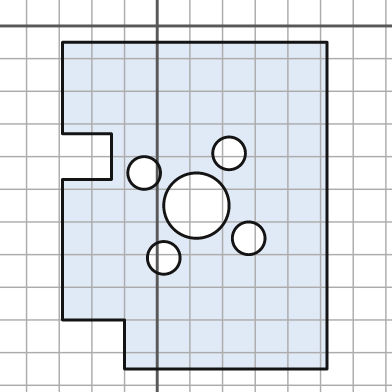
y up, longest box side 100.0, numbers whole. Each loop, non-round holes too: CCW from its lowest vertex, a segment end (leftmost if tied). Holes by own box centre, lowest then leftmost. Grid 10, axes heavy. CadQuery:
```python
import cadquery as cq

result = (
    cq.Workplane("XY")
    .moveTo(-10.0, -105.0)
    .lineTo(52.0, -105.0)
    .lineTo(52.0, -5.0)
    .lineTo(-29.0, -5.0)
    .lineTo(-29.0, -33.0)
    .lineTo(-14.0, -33.0)
    .lineTo(-14.0, -47.0)
    .lineTo(-29.0, -47.0)
    .lineTo(-29.0, -90.0)
    .lineTo(-10.0, -90.0)
    .close()
    .moveTo(2.0, -71.0)
    .circle(5.0)
    .moveTo(28.0, -65.0)
    .circle(5.0)
    .moveTo(12.0, -55.0)
    .circle(10.0)
    .moveTo(-4.0, -45.0)
    .circle(5.0)
    .moveTo(22.0, -39.0)
    .circle(5.0)
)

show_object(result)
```